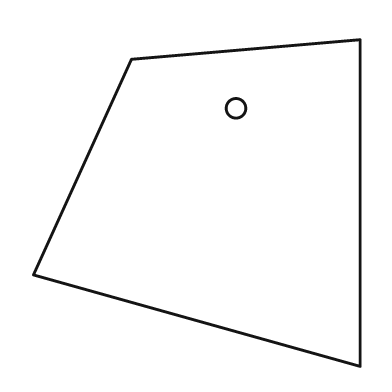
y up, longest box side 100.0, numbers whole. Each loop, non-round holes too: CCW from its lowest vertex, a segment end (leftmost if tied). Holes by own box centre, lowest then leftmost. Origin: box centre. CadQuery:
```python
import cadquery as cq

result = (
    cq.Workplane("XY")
    .moveTo(50.0, -50.0)
    .lineTo(50.0, 50.0)
    .lineTo(-20.0, 44.0)
    .lineTo(-50.0, -22.0)
    .close()
    .moveTo(12.0, 29.0)
    .circle(3.0)
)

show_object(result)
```